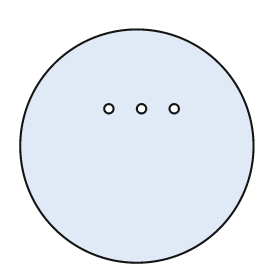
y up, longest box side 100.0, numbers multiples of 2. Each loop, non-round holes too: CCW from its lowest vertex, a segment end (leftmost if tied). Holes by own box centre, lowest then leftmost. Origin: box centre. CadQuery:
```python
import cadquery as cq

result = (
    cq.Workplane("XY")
    .moveTo(0.0, 0.0)
    .circle(50.0)
    .moveTo(-12.0, 16.0)
    .circle(2.0)
    .moveTo(2.0, 16.0)
    .circle(2.0)
    .moveTo(16.0, 16.0)
    .circle(2.0)
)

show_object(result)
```